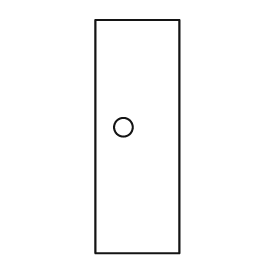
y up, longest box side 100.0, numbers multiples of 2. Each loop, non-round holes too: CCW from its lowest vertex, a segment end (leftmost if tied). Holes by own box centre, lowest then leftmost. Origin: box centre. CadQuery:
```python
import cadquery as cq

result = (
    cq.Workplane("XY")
    .moveTo(-18.0, -50.0)
    .lineTo(18.0, -50.0)
    .lineTo(18.0, 50.0)
    .lineTo(-18.0, 50.0)
    .close()
    .moveTo(-6.0, 4.0)
    .circle(4.0)
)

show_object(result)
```